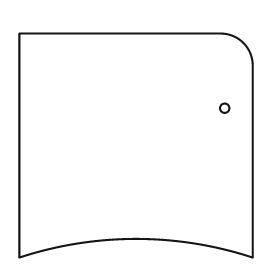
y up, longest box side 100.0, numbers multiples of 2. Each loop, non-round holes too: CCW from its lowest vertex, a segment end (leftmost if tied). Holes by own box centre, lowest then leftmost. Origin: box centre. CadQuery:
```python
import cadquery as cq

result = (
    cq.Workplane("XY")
    .moveTo(-50.0, -48.0)
    .threePointArc((0.0, -40.0), (50.0, -48.0))
    .lineTo(50.0, 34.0)
    .threePointArc((46.0, 44.0), (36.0, 48.0))
    .lineTo(-50.0, 48.0)
    .close()
    .moveTo(38.0, 16.0)
    .circle(2.0)
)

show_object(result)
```